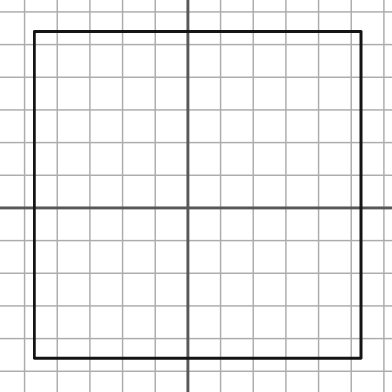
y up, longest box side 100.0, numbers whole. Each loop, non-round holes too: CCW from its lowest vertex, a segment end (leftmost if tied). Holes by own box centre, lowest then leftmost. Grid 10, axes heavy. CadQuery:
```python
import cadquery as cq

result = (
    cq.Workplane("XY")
    .moveTo(-47.0, -46.0)
    .lineTo(53.0, -46.0)
    .lineTo(53.0, 54.0)
    .lineTo(-47.0, 54.0)
    .close()
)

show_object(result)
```